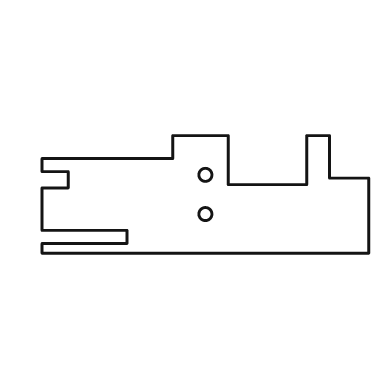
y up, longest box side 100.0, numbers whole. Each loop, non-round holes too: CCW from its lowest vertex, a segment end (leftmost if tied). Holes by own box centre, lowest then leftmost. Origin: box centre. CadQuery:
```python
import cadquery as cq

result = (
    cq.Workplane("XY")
    .moveTo(-50.0, -18.0)
    .lineTo(50.0, -18.0)
    .lineTo(50.0, 5.0)
    .lineTo(38.0, 5.0)
    .lineTo(38.0, 18.0)
    .lineTo(31.0, 18.0)
    .lineTo(31.0, 3.0)
    .lineTo(7.0, 3.0)
    .lineTo(7.0, 18.0)
    .lineTo(-10.0, 18.0)
    .lineTo(-10.0, 11.0)
    .lineTo(-50.0, 11.0)
    .lineTo(-50.0, 7.0)
    .lineTo(-42.0, 7.0)
    .lineTo(-42.0, 2.0)
    .lineTo(-50.0, 2.0)
    .lineTo(-50.0, -11.0)
    .lineTo(-24.0, -11.0)
    .lineTo(-24.0, -15.0)
    .lineTo(-50.0, -15.0)
    .close()
    .moveTo(0.0, -6.0)
    .circle(2.0)
    .moveTo(0.0, 6.0)
    .circle(2.0)
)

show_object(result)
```